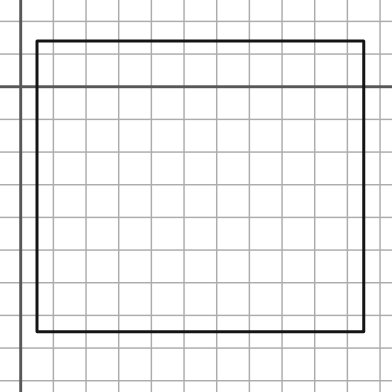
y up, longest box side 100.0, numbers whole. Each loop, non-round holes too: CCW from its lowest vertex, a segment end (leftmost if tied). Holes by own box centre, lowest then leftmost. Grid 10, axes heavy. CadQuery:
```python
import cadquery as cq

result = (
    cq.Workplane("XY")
    .moveTo(5.0, -75.0)
    .lineTo(105.0, -75.0)
    .lineTo(105.0, 14.0)
    .lineTo(5.0, 14.0)
    .close()
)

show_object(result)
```